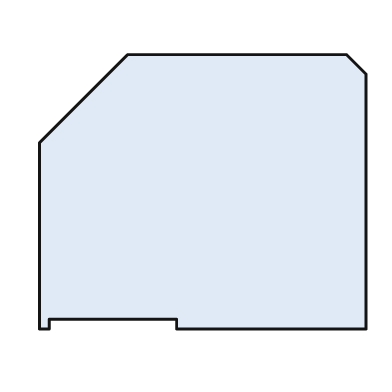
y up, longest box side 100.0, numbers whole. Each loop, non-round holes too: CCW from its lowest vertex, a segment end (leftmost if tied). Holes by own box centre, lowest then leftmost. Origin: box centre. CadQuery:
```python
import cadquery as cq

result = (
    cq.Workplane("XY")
    .moveTo(-50.0, -42.0)
    .lineTo(-47.0, -42.0)
    .lineTo(-47.0, -39.0)
    .lineTo(-8.0, -39.0)
    .lineTo(-8.0, -42.0)
    .lineTo(50.0, -42.0)
    .lineTo(50.0, 36.0)
    .lineTo(44.0, 42.0)
    .lineTo(-23.0, 42.0)
    .lineTo(-50.0, 15.0)
    .close()
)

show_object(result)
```